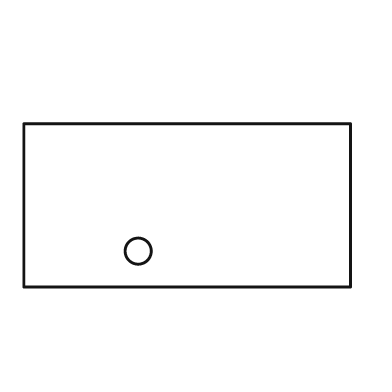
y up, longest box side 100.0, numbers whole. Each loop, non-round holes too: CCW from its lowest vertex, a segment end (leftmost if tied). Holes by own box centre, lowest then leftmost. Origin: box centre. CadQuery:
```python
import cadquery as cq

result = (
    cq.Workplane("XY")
    .moveTo(-50.0, -25.0)
    .lineTo(50.0, -25.0)
    .lineTo(50.0, 25.0)
    .lineTo(-50.0, 25.0)
    .close()
    .moveTo(-15.0, -14.0)
    .circle(4.0)
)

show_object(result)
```